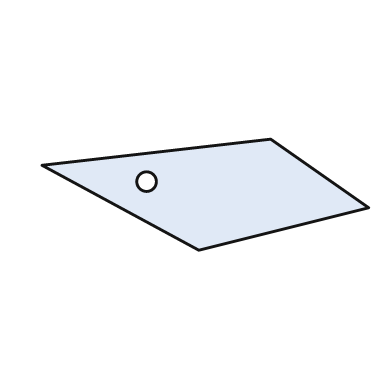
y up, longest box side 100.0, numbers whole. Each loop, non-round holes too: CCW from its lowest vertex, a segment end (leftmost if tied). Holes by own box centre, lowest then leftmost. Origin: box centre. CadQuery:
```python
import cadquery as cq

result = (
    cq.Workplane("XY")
    .moveTo(-2.0, -17.0)
    .lineTo(50.0, -4.0)
    .lineTo(20.0, 17.0)
    .lineTo(-50.0, 9.0)
    .close()
    .moveTo(-18.0, 4.0)
    .circle(3.0)
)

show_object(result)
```